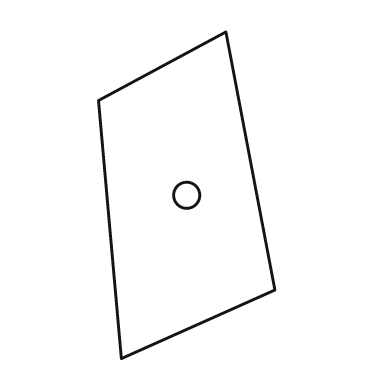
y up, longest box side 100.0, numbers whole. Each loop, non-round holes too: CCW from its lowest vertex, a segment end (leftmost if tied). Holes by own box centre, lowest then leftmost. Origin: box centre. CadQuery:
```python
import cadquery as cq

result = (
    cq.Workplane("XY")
    .moveTo(-20.0, -50.0)
    .lineTo(27.0, -29.0)
    .lineTo(12.0, 50.0)
    .lineTo(-27.0, 29.0)
    .close()
    .moveTo(0.0, 0.0)
    .circle(4.0)
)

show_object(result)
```